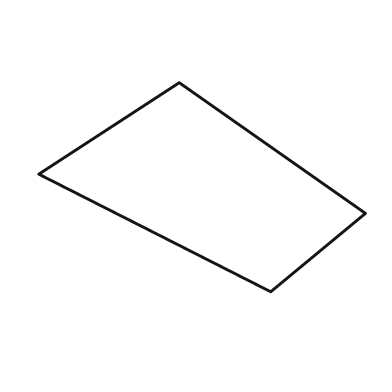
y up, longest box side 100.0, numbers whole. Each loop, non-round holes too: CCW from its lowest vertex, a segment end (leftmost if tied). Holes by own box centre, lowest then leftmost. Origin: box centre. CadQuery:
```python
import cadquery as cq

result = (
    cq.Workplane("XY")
    .moveTo(21.0, -32.0)
    .lineTo(50.0, -8.0)
    .lineTo(-7.0, 32.0)
    .lineTo(-50.0, 4.0)
    .close()
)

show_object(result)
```